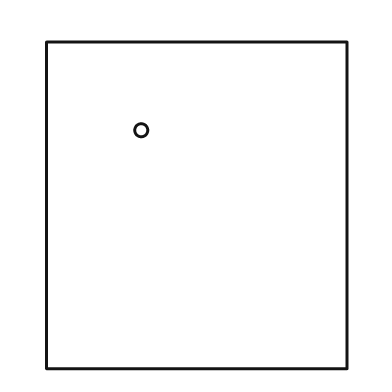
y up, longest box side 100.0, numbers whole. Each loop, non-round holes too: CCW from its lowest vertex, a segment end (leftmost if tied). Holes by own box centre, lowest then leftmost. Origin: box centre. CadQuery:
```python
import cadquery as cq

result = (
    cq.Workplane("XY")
    .moveTo(-46.0, -50.0)
    .lineTo(46.0, -50.0)
    .lineTo(46.0, 50.0)
    .lineTo(-46.0, 50.0)
    .close()
    .moveTo(-17.0, 23.0)
    .circle(2.0)
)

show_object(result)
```